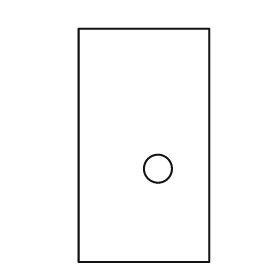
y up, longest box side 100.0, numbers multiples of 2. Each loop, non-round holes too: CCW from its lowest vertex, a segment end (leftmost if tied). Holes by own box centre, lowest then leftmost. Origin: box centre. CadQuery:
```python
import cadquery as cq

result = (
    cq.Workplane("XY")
    .moveTo(-28.0, -50.0)
    .lineTo(28.0, -50.0)
    .lineTo(28.0, 50.0)
    .lineTo(-28.0, 50.0)
    .close()
    .moveTo(6.0, -10.0)
    .circle(6.0)
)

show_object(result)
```